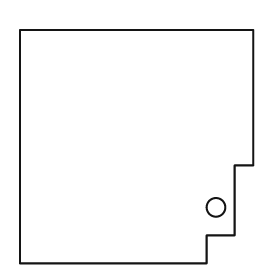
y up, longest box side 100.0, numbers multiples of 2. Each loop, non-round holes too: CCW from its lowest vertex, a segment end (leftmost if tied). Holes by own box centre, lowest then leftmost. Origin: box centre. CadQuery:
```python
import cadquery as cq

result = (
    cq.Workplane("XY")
    .moveTo(-50.0, -50.0)
    .lineTo(30.0, -50.0)
    .lineTo(30.0, -38.0)
    .lineTo(42.0, -38.0)
    .lineTo(42.0, -8.0)
    .lineTo(50.0, -8.0)
    .lineTo(50.0, 50.0)
    .lineTo(-50.0, 50.0)
    .close()
    .moveTo(34.0, -26.0)
    .circle(4.0)
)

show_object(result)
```